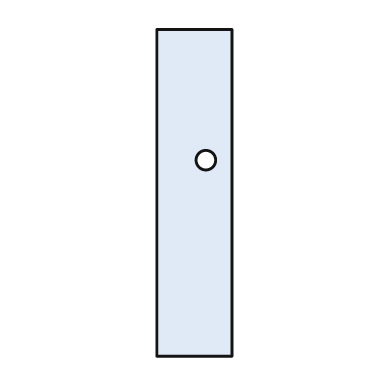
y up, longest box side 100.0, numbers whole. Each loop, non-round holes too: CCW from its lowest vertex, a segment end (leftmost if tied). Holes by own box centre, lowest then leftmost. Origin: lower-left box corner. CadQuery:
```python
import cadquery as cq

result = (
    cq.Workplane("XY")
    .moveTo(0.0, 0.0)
    .lineTo(23.0, 0.0)
    .lineTo(23.0, 100.0)
    .lineTo(0.0, 100.0)
    .close()
    .moveTo(15.0, 60.0)
    .circle(3.0)
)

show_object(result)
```